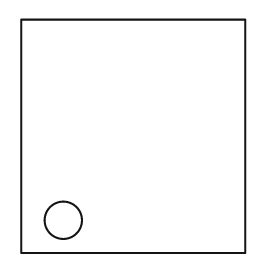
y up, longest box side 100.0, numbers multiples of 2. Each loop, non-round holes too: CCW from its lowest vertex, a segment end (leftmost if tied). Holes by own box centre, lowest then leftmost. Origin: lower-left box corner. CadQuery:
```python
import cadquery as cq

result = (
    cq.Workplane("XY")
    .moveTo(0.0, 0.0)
    .lineTo(96.0, 0.0)
    .lineTo(96.0, 100.0)
    .lineTo(0.0, 100.0)
    .close()
    .moveTo(18.0, 14.0)
    .circle(8.0)
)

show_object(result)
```